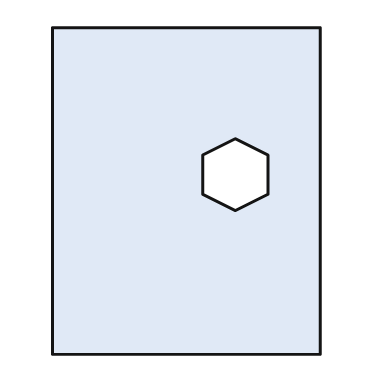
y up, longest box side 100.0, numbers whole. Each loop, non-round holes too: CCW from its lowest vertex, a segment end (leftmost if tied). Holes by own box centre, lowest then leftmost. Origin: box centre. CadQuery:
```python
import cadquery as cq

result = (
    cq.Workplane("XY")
    .moveTo(-41.0, -50.0)
    .lineTo(41.0, -50.0)
    .lineTo(41.0, 50.0)
    .lineTo(-41.0, 50.0)
    .close()
    .moveTo(15.0, -6.0)
    .lineTo(25.0, -1.0)
    .lineTo(25.0, 11.0)
    .lineTo(15.0, 16.0)
    .lineTo(5.0, 11.0)
    .lineTo(5.0, -1.0)
    .close()
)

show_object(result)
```